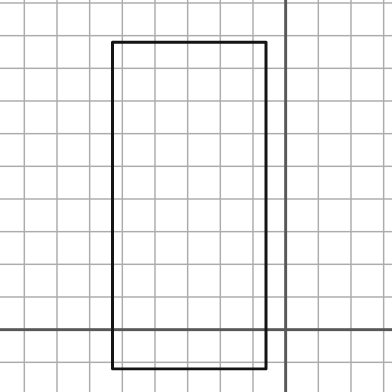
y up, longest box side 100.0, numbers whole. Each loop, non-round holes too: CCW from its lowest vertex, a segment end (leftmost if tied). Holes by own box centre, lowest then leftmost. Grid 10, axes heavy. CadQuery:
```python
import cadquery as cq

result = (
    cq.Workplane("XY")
    .moveTo(-53.0, -12.0)
    .lineTo(-6.0, -12.0)
    .lineTo(-6.0, 88.0)
    .lineTo(-53.0, 88.0)
    .close()
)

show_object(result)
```